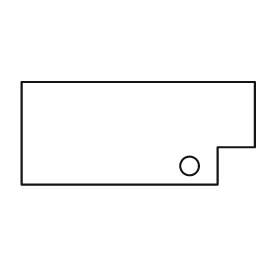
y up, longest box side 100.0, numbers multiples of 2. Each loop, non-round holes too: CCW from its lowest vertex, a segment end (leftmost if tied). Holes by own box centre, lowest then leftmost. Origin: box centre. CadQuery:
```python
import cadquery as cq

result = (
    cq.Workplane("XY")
    .moveTo(-50.0, -22.0)
    .lineTo(34.0, -22.0)
    .lineTo(34.0, -6.0)
    .lineTo(50.0, -6.0)
    .lineTo(50.0, 22.0)
    .lineTo(-50.0, 22.0)
    .close()
    .moveTo(22.0, -14.0)
    .circle(4.0)
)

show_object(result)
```